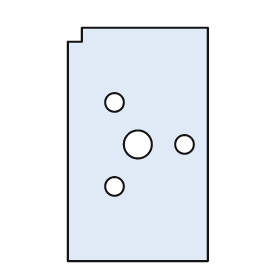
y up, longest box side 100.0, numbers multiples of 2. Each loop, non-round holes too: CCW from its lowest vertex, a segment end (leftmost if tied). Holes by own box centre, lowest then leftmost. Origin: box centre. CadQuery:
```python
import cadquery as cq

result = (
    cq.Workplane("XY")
    .moveTo(-30.0, -50.0)
    .lineTo(30.0, -50.0)
    .lineTo(30.0, 50.0)
    .lineTo(-24.0, 50.0)
    .lineTo(-24.0, 44.0)
    .lineTo(-30.0, 44.0)
    .close()
    .moveTo(-10.0, -18.0)
    .circle(4.0)
    .moveTo(0.0, 0.0)
    .circle(6.0)
    .moveTo(20.0, 0.0)
    .circle(4.0)
    .moveTo(-10.0, 18.0)
    .circle(4.0)
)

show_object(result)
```